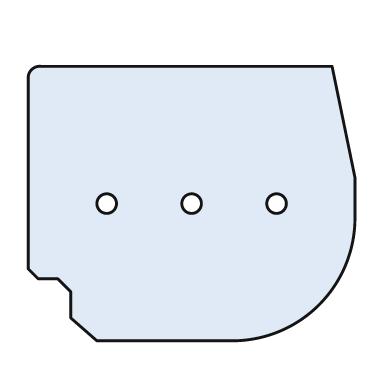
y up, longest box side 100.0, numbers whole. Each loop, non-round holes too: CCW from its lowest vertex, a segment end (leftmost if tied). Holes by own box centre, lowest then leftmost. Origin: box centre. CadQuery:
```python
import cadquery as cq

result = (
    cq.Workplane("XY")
    .moveTo(-29.0, -42.0)
    .lineTo(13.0, -42.0)
    .threePointArc((39.0, -31.0), (50.0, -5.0))
    .lineTo(50.0, 8.0)
    .lineTo(43.0, 42.0)
    .lineTo(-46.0, 42.0)
    .threePointArc((-49.0, 41.0), (-50.0, 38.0))
    .lineTo(-50.0, -20.0)
    .lineTo(-47.0, -23.0)
    .lineTo(-41.0, -23.0)
    .lineTo(-37.0, -27.0)
    .lineTo(-37.0, -35.0)
    .close()
    .moveTo(-26.0, 0.0)
    .circle(3.0)
    .moveTo(0.0, 0.0)
    .circle(3.0)
    .moveTo(26.0, 0.0)
    .circle(3.0)
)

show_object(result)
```